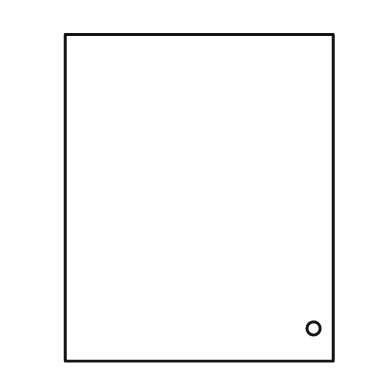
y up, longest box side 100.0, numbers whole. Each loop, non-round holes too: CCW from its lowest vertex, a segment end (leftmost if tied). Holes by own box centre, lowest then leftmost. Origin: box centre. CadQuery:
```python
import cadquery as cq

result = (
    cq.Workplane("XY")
    .moveTo(-41.0, -50.0)
    .lineTo(41.0, -50.0)
    .lineTo(41.0, 50.0)
    .lineTo(-41.0, 50.0)
    .close()
    .moveTo(35.0, -40.0)
    .circle(2.0)
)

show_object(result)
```